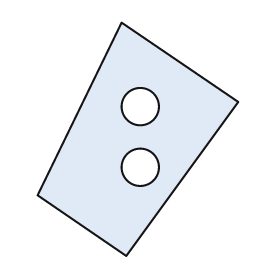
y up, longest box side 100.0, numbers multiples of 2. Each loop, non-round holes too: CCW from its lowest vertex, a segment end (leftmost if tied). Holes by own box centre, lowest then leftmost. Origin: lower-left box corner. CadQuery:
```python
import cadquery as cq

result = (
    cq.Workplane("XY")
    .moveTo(38.0, 0.0)
    .lineTo(86.0, 66.0)
    .lineTo(36.0, 100.0)
    .lineTo(0.0, 26.0)
    .close()
    .moveTo(44.0, 38.0)
    .circle(8.0)
    .moveTo(44.0, 64.0)
    .circle(8.0)
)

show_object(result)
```